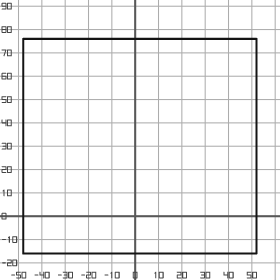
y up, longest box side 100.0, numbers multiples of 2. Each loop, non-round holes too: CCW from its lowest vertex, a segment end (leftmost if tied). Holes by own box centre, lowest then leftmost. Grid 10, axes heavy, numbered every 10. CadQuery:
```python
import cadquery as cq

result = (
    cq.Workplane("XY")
    .moveTo(-48.0, -16.0)
    .lineTo(52.0, -16.0)
    .lineTo(52.0, 76.0)
    .lineTo(-48.0, 76.0)
    .close()
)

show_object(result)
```